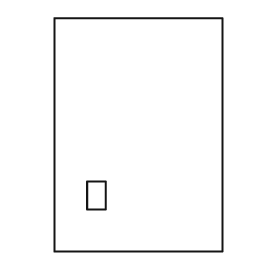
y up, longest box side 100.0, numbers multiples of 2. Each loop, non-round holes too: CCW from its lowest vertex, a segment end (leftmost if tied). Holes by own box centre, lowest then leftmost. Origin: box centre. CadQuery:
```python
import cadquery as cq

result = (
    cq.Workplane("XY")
    .moveTo(-36.0, -50.0)
    .lineTo(36.0, -50.0)
    .lineTo(36.0, 50.0)
    .lineTo(-36.0, 50.0)
    .close()
    .moveTo(-22.0, -32.0)
    .lineTo(-14.0, -32.0)
    .lineTo(-14.0, -20.0)
    .lineTo(-22.0, -20.0)
    .close()
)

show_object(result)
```